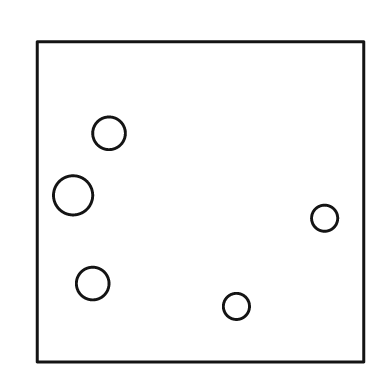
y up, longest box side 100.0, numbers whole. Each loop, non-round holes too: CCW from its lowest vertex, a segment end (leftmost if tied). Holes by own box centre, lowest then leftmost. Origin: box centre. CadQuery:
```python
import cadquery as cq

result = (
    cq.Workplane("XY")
    .moveTo(-50.0, -49.0)
    .lineTo(50.0, -49.0)
    .lineTo(50.0, 49.0)
    .lineTo(-50.0, 49.0)
    .close()
    .moveTo(11.0, -32.0)
    .circle(4.0)
    .moveTo(-33.0, -25.0)
    .circle(5.0)
    .moveTo(38.0, -5.0)
    .circle(4.0)
    .moveTo(-39.0, 2.0)
    .circle(6.0)
    .moveTo(-28.0, 21.0)
    .circle(5.0)
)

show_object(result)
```